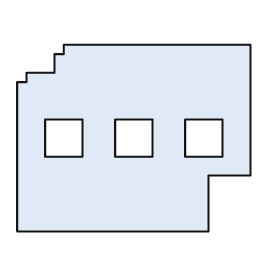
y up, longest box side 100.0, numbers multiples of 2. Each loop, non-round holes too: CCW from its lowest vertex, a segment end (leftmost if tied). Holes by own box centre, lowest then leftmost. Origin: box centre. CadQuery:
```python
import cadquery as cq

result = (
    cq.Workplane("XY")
    .moveTo(-50.0, -40.0)
    .lineTo(32.0, -40.0)
    .lineTo(32.0, -16.0)
    .lineTo(50.0, -16.0)
    .lineTo(50.0, 40.0)
    .lineTo(-30.0, 40.0)
    .lineTo(-30.0, 36.0)
    .lineTo(-34.0, 36.0)
    .lineTo(-34.0, 28.0)
    .lineTo(-46.0, 28.0)
    .lineTo(-46.0, 24.0)
    .lineTo(-50.0, 24.0)
    .close()
    .moveTo(-38.0, -8.0)
    .lineTo(-22.0, -8.0)
    .lineTo(-22.0, 8.0)
    .lineTo(-38.0, 8.0)
    .close()
    .moveTo(-8.0, -8.0)
    .lineTo(8.0, -8.0)
    .lineTo(8.0, 8.0)
    .lineTo(-8.0, 8.0)
    .close()
    .moveTo(22.0, -8.0)
    .lineTo(38.0, -8.0)
    .lineTo(38.0, 8.0)
    .lineTo(22.0, 8.0)
    .close()
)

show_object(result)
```